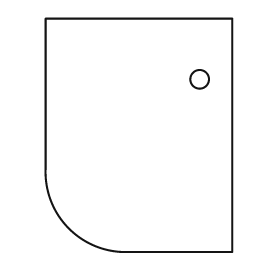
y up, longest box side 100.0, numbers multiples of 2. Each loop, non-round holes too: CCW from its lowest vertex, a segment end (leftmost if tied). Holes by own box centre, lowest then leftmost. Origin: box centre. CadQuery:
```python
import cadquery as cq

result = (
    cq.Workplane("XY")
    .moveTo(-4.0, -50.0)
    .lineTo(40.0, -50.0)
    .lineTo(40.0, 50.0)
    .lineTo(-40.0, 50.0)
    .lineTo(-40.0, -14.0)
    .threePointArc((-30.0, -40.0), (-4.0, -50.0))
    .close()
    .moveTo(26.0, 24.0)
    .circle(4.0)
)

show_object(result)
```